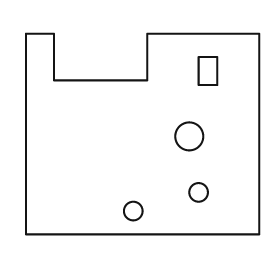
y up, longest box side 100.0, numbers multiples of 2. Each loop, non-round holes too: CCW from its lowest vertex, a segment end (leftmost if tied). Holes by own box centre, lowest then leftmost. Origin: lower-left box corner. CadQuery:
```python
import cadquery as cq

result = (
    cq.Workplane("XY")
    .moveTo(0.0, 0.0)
    .lineTo(100.0, 0.0)
    .lineTo(100.0, 86.0)
    .lineTo(52.0, 86.0)
    .lineTo(52.0, 66.0)
    .lineTo(12.0, 66.0)
    .lineTo(12.0, 86.0)
    .lineTo(0.0, 86.0)
    .close()
    .moveTo(46.0, 10.0)
    .circle(4.0)
    .moveTo(74.0, 18.0)
    .circle(4.0)
    .moveTo(70.0, 42.0)
    .circle(6.0)
    .moveTo(74.0, 64.0)
    .lineTo(82.0, 64.0)
    .lineTo(82.0, 76.0)
    .lineTo(74.0, 76.0)
    .close()
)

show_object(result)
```